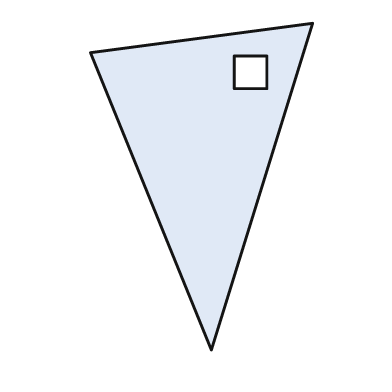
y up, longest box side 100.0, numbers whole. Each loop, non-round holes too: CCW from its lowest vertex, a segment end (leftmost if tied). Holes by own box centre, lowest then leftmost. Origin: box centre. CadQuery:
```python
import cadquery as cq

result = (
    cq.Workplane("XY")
    .moveTo(3.0, -50.0)
    .lineTo(34.0, 50.0)
    .lineTo(-34.0, 41.0)
    .close()
    .moveTo(10.0, 30.0)
    .lineTo(20.0, 30.0)
    .lineTo(20.0, 40.0)
    .lineTo(10.0, 40.0)
    .close()
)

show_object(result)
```